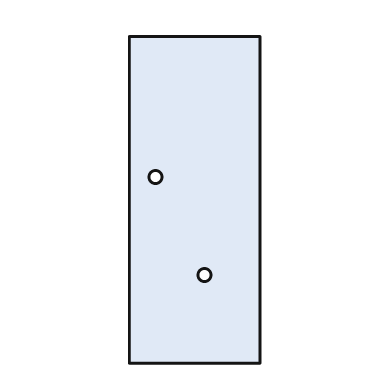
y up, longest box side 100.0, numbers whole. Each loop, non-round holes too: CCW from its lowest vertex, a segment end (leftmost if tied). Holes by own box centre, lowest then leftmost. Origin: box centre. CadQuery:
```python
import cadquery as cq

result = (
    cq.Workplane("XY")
    .moveTo(-20.0, -50.0)
    .lineTo(20.0, -50.0)
    .lineTo(20.0, 50.0)
    .lineTo(-20.0, 50.0)
    .close()
    .moveTo(3.0, -23.0)
    .circle(2.0)
    .moveTo(-12.0, 7.0)
    .circle(2.0)
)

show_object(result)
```